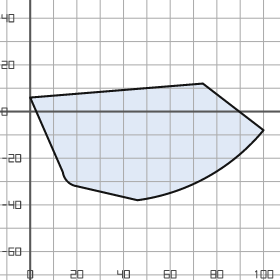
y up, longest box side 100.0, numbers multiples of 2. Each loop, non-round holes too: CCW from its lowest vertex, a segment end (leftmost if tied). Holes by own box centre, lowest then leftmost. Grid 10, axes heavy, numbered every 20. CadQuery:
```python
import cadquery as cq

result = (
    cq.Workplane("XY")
    .moveTo(46.0, -38.0)
    .threePointArc((76.0, -28.0), (100.0, -8.0))
    .lineTo(74.0, 12.0)
    .lineTo(0.0, 6.0)
    .lineTo(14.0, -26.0)
    .threePointArc((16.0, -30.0), (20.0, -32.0))
    .close()
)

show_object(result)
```